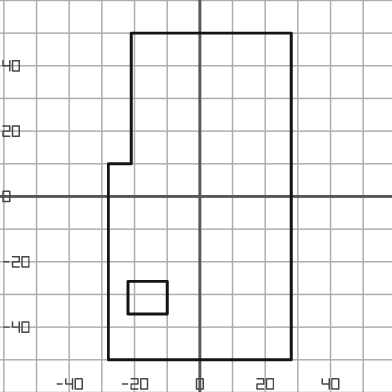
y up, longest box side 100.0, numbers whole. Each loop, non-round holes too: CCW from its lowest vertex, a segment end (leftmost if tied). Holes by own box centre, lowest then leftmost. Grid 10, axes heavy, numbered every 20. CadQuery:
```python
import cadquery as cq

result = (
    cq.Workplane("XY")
    .moveTo(-28.0, -50.0)
    .lineTo(28.0, -50.0)
    .lineTo(28.0, 50.0)
    .lineTo(-21.0, 50.0)
    .lineTo(-21.0, 10.0)
    .lineTo(-28.0, 10.0)
    .close()
    .moveTo(-22.0, -36.0)
    .lineTo(-10.0, -36.0)
    .lineTo(-10.0, -26.0)
    .lineTo(-22.0, -26.0)
    .close()
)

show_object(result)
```